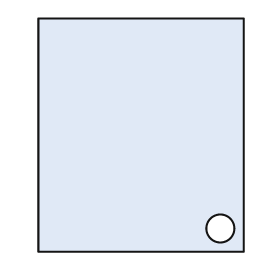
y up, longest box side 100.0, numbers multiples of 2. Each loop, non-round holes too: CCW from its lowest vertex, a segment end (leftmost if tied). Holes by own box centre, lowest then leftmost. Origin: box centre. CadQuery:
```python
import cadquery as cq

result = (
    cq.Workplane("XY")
    .moveTo(-44.0, -50.0)
    .lineTo(44.0, -50.0)
    .lineTo(44.0, 50.0)
    .lineTo(-44.0, 50.0)
    .close()
    .moveTo(34.0, -40.0)
    .circle(6.0)
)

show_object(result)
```